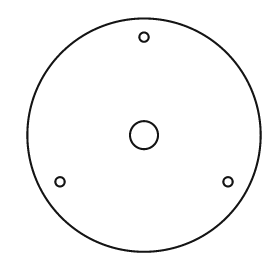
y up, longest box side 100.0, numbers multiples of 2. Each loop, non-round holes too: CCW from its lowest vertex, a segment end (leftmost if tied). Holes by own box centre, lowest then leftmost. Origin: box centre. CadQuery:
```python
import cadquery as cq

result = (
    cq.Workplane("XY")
    .moveTo(0.0, 0.0)
    .circle(50.0)
    .moveTo(-36.0, -20.0)
    .circle(2.0)
    .moveTo(36.0, -20.0)
    .circle(2.0)
    .moveTo(0.0, 0.0)
    .circle(6.0)
    .moveTo(0.0, 42.0)
    .circle(2.0)
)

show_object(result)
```